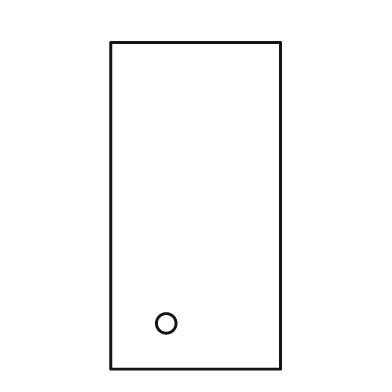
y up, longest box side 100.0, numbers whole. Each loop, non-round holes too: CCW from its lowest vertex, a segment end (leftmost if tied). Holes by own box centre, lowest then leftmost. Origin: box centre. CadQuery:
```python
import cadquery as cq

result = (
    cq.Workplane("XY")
    .moveTo(-26.0, -50.0)
    .lineTo(26.0, -50.0)
    .lineTo(26.0, 50.0)
    .lineTo(-26.0, 50.0)
    .close()
    .moveTo(-9.0, -36.0)
    .circle(3.0)
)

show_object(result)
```